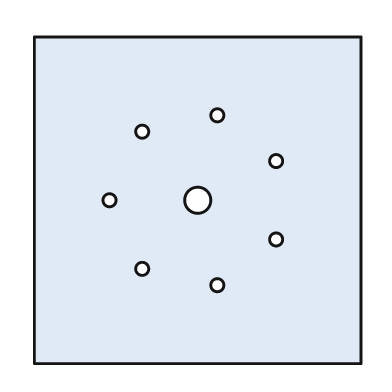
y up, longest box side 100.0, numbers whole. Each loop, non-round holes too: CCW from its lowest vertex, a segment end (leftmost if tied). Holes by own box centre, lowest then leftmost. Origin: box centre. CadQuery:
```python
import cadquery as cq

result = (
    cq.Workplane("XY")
    .moveTo(-50.0, -50.0)
    .lineTo(50.0, -50.0)
    .lineTo(50.0, 50.0)
    .lineTo(-50.0, 50.0)
    .close()
    .moveTo(6.0, -26.0)
    .circle(2.0)
    .moveTo(-17.0, -21.0)
    .circle(2.0)
    .moveTo(24.0, -12.0)
    .circle(2.0)
    .moveTo(-27.0, 0.0)
    .circle(2.0)
    .moveTo(0.0, 0.0)
    .circle(4.0)
    .moveTo(24.0, 12.0)
    .circle(2.0)
    .moveTo(-17.0, 21.0)
    .circle(2.0)
    .moveTo(6.0, 26.0)
    .circle(2.0)
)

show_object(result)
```